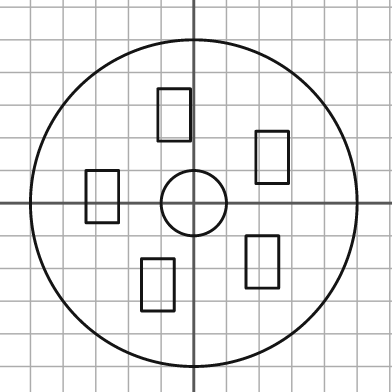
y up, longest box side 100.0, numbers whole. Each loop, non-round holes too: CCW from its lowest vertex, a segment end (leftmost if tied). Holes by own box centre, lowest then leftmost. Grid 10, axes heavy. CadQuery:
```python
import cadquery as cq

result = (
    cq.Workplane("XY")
    .moveTo(0.0, 0.0)
    .circle(50.0)
    .moveTo(-16.0, -33.0)
    .lineTo(-6.0, -33.0)
    .lineTo(-6.0, -17.0)
    .lineTo(-16.0, -17.0)
    .close()
    .moveTo(16.0, -26.0)
    .lineTo(26.0, -26.0)
    .lineTo(26.0, -10.0)
    .lineTo(16.0, -10.0)
    .close()
    .moveTo(0.0, 0.0)
    .circle(10.0)
    .moveTo(-33.0, -6.0)
    .lineTo(-23.0, -6.0)
    .lineTo(-23.0, 10.0)
    .lineTo(-33.0, 10.0)
    .close()
    .moveTo(19.0, 6.0)
    .lineTo(29.0, 6.0)
    .lineTo(29.0, 22.0)
    .lineTo(19.0, 22.0)
    .close()
    .moveTo(-11.0, 19.0)
    .lineTo(-1.0, 19.0)
    .lineTo(-1.0, 35.0)
    .lineTo(-11.0, 35.0)
    .close()
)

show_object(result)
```